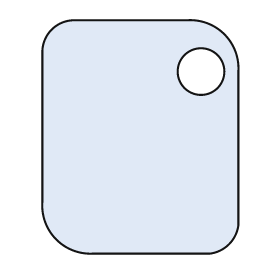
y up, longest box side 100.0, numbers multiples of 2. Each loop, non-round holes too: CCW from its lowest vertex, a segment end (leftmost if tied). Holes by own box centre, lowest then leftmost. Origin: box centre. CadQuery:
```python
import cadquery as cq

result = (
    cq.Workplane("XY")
    .moveTo(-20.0, -50.0)
    .lineTo(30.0, -50.0)
    .threePointArc((38.0, -46.0), (42.0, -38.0))
    .lineTo(42.0, 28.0)
    .threePointArc((36.0, 44.0), (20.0, 50.0))
    .lineTo(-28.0, 50.0)
    .threePointArc((-38.0, 46.0), (-42.0, 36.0))
    .lineTo(-42.0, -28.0)
    .threePointArc((-36.0, -44.0), (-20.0, -50.0))
    .close()
    .moveTo(26.0, 28.0)
    .circle(10.0)
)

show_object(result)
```